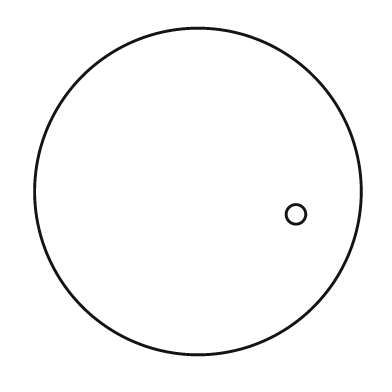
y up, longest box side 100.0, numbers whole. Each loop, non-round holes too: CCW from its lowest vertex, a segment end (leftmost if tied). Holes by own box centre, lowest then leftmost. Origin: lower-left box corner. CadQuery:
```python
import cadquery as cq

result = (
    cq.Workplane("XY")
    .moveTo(50.0, 50.0)
    .circle(50.0)
    .moveTo(80.0, 43.0)
    .circle(3.0)
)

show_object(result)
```